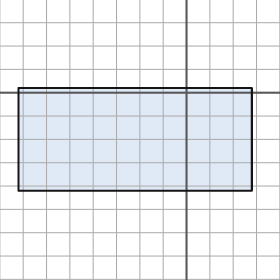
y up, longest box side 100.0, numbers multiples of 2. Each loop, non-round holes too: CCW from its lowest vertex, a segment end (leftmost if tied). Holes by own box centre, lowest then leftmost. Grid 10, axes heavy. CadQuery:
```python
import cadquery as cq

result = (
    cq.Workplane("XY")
    .moveTo(-72.0, -42.0)
    .lineTo(28.0, -42.0)
    .lineTo(28.0, 2.0)
    .lineTo(-72.0, 2.0)
    .close()
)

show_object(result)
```